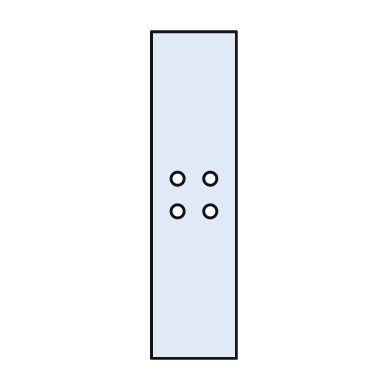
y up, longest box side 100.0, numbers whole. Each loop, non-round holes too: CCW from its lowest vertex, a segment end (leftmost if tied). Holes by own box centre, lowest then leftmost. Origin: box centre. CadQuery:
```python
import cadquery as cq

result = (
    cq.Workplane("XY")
    .moveTo(-13.0, -50.0)
    .lineTo(13.0, -50.0)
    .lineTo(13.0, 50.0)
    .lineTo(-13.0, 50.0)
    .close()
    .moveTo(-5.0, -5.0)
    .circle(2.0)
    .moveTo(5.0, -5.0)
    .circle(2.0)
    .moveTo(-5.0, 5.0)
    .circle(2.0)
    .moveTo(5.0, 5.0)
    .circle(2.0)
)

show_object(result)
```